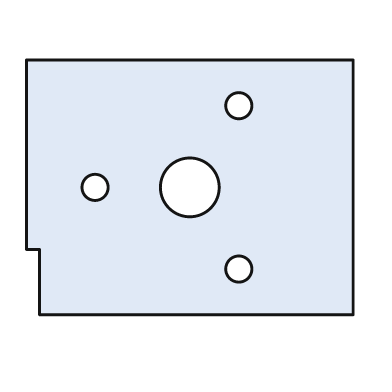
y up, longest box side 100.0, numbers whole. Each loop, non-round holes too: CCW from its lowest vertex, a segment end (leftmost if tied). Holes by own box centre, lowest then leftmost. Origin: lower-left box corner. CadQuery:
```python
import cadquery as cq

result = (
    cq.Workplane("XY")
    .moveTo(4.0, 0.0)
    .lineTo(100.0, 0.0)
    .lineTo(100.0, 78.0)
    .lineTo(0.0, 78.0)
    .lineTo(0.0, 20.0)
    .lineTo(4.0, 20.0)
    .close()
    .moveTo(65.0, 14.0)
    .circle(4.0)
    .moveTo(21.0, 39.0)
    .circle(4.0)
    .moveTo(50.0, 39.0)
    .circle(9.0)
    .moveTo(65.0, 64.0)
    .circle(4.0)
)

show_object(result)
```